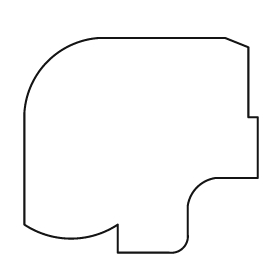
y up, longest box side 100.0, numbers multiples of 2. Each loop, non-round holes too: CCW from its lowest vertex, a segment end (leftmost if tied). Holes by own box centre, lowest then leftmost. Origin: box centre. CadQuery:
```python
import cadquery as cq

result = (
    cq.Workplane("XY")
    .moveTo(-10.0, -46.0)
    .lineTo(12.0, -46.0)
    .threePointArc((18.0, -44.0), (20.0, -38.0))
    .lineTo(20.0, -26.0)
    .threePointArc((24.0, -18.0), (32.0, -14.0))
    .lineTo(50.0, -14.0)
    .lineTo(50.0, 12.0)
    .lineTo(46.0, 12.0)
    .lineTo(46.0, 42.0)
    .lineTo(36.0, 46.0)
    .lineTo(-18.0, 46.0)
    .threePointArc((-40.0, 36.0), (-50.0, 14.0))
    .lineTo(-50.0, -34.0)
    .threePointArc((-30.0, -40.0), (-10.0, -34.0))
    .close()
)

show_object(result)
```